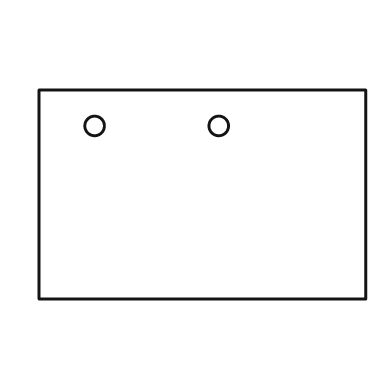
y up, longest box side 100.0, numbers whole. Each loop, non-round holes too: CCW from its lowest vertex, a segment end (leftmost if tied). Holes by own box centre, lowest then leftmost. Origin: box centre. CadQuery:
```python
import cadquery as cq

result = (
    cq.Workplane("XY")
    .moveTo(-50.0, -32.0)
    .lineTo(50.0, -32.0)
    .lineTo(50.0, 32.0)
    .lineTo(-50.0, 32.0)
    .close()
    .moveTo(-33.0, 21.0)
    .circle(3.0)
    .moveTo(5.0, 21.0)
    .circle(3.0)
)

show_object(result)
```